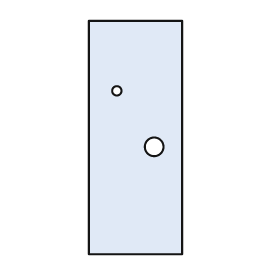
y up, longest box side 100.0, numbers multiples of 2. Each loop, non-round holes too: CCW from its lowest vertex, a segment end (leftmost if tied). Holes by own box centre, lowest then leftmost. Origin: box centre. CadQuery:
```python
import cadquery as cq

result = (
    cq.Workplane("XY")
    .moveTo(-20.0, -50.0)
    .lineTo(20.0, -50.0)
    .lineTo(20.0, 50.0)
    .lineTo(-20.0, 50.0)
    .close()
    .moveTo(8.0, -4.0)
    .circle(4.0)
    .moveTo(-8.0, 20.0)
    .circle(2.0)
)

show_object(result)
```